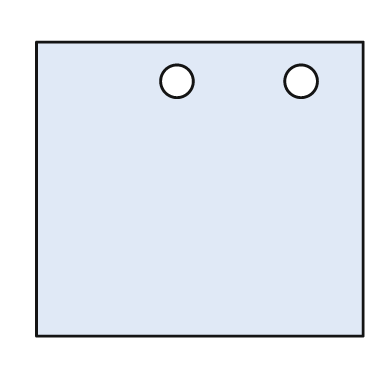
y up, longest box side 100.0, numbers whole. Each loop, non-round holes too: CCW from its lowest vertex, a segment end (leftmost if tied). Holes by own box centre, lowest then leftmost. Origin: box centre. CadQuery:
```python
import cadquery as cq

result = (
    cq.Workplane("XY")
    .moveTo(-50.0, -45.0)
    .lineTo(50.0, -45.0)
    .lineTo(50.0, 45.0)
    .lineTo(-50.0, 45.0)
    .close()
    .moveTo(-7.0, 33.0)
    .circle(5.0)
    .moveTo(31.0, 33.0)
    .circle(5.0)
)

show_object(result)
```